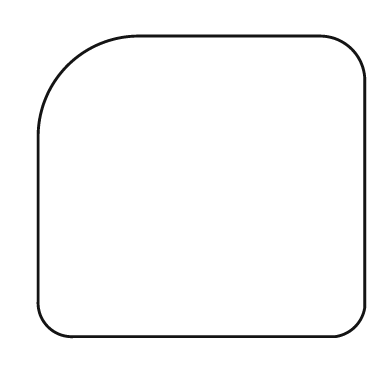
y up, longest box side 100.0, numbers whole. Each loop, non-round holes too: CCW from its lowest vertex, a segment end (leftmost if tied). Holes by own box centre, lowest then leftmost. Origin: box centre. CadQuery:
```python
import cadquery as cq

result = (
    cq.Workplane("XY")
    .moveTo(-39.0, -46.0)
    .lineTo(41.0, -46.0)
    .threePointArc((47.0, -43.0), (50.0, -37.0))
    .lineTo(50.0, 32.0)
    .threePointArc((46.0, 42.0), (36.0, 46.0))
    .lineTo(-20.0, 46.0)
    .threePointArc((-41.0, 37.0), (-50.0, 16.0))
    .lineTo(-50.0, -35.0)
    .threePointArc((-47.0, -43.0), (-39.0, -46.0))
    .close()
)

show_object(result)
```